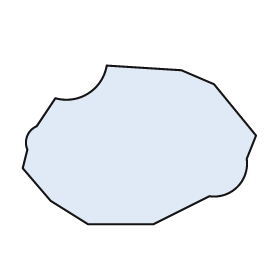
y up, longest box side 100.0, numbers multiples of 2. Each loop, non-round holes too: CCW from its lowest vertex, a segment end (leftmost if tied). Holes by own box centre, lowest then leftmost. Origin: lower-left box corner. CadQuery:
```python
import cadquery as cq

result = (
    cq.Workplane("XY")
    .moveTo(28.0, 0.0)
    .lineTo(56.0, 0.0)
    .lineTo(80.0, 12.0)
    .threePointArc((92.0, 16.0), (96.0, 28.0))
    .lineTo(100.0, 38.0)
    .lineTo(82.0, 60.0)
    .lineTo(68.0, 66.0)
    .lineTo(36.0, 68.0)
    .threePointArc((28.0, 56.0), (14.0, 54.0))
    .lineTo(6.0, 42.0)
    .threePointArc((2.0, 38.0), (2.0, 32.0))
    .lineTo(0.0, 24.0)
    .lineTo(12.0, 10.0)
    .close()
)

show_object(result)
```